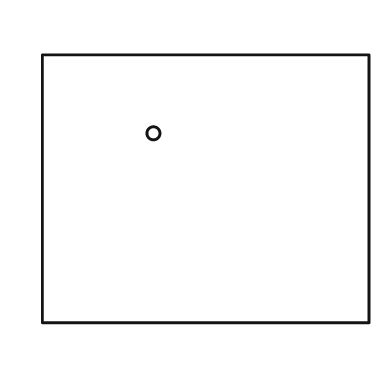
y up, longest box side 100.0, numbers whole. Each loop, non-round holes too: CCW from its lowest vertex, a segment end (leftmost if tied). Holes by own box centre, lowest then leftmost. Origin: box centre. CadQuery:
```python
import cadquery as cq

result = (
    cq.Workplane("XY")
    .moveTo(-50.0, -41.0)
    .lineTo(50.0, -41.0)
    .lineTo(50.0, 41.0)
    .lineTo(-50.0, 41.0)
    .close()
    .moveTo(-16.0, 17.0)
    .circle(2.0)
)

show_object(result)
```